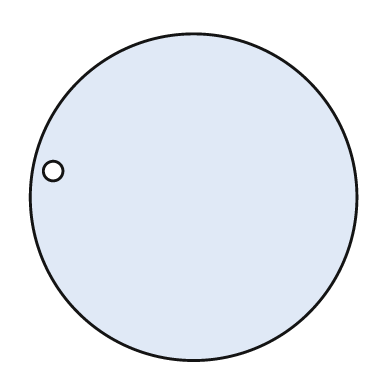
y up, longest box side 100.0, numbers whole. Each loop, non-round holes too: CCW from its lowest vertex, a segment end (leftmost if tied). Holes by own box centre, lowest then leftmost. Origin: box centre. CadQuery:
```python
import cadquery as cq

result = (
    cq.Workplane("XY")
    .moveTo(0.0, 0.0)
    .circle(50.0)
    .moveTo(-43.0, 8.0)
    .circle(3.0)
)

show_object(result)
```